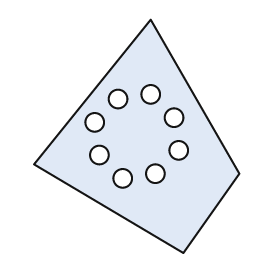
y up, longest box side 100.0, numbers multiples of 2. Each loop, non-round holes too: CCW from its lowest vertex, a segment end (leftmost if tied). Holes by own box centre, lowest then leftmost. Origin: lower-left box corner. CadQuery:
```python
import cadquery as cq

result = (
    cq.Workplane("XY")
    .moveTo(64.0, 0.0)
    .lineTo(88.0, 34.0)
    .lineTo(50.0, 100.0)
    .lineTo(0.0, 38.0)
    .close()
    .moveTo(38.0, 32.0)
    .circle(4.0)
    .moveTo(52.0, 34.0)
    .circle(4.0)
    .moveTo(28.0, 42.0)
    .circle(4.0)
    .moveTo(62.0, 44.0)
    .circle(4.0)
    .moveTo(26.0, 56.0)
    .circle(4.0)
    .moveTo(60.0, 58.0)
    .circle(4.0)
    .moveTo(36.0, 66.0)
    .circle(4.0)
    .moveTo(50.0, 68.0)
    .circle(4.0)
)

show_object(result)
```